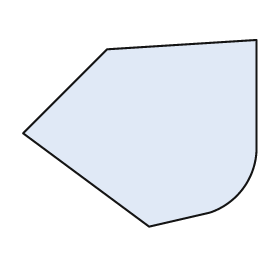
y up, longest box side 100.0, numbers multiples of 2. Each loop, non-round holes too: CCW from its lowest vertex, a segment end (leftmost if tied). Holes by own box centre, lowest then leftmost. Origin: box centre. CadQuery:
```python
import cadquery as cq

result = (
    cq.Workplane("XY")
    .moveTo(4.0, -40.0)
    .lineTo(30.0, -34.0)
    .threePointArc((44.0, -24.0), (50.0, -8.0))
    .lineTo(50.0, 40.0)
    .lineTo(-14.0, 36.0)
    .lineTo(-50.0, 0.0)
    .close()
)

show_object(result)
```